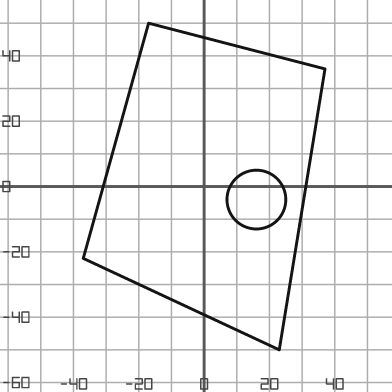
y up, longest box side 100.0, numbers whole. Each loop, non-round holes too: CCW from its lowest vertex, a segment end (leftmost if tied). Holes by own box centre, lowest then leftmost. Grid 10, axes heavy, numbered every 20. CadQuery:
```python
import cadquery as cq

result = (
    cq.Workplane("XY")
    .moveTo(23.0, -50.0)
    .lineTo(37.0, 36.0)
    .lineTo(-17.0, 50.0)
    .lineTo(-37.0, -22.0)
    .close()
    .moveTo(16.0, -4.0)
    .circle(9.0)
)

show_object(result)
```